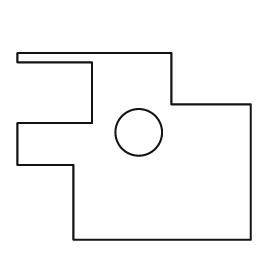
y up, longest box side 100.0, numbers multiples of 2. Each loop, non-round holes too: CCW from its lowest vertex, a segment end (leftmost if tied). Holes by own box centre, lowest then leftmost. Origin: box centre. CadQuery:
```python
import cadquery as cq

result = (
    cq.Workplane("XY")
    .moveTo(-26.0, -40.0)
    .lineTo(50.0, -40.0)
    .lineTo(50.0, 18.0)
    .lineTo(16.0, 18.0)
    .lineTo(16.0, 40.0)
    .lineTo(-50.0, 40.0)
    .lineTo(-50.0, 36.0)
    .lineTo(-18.0, 36.0)
    .lineTo(-18.0, 10.0)
    .lineTo(-50.0, 10.0)
    .lineTo(-50.0, -8.0)
    .lineTo(-26.0, -8.0)
    .close()
    .moveTo(2.0, 6.0)
    .circle(10.0)
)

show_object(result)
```